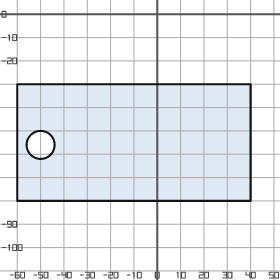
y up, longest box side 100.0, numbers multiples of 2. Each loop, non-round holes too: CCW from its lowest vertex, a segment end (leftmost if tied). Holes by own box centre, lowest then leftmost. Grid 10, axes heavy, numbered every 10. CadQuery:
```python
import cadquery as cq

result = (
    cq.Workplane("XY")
    .moveTo(-60.0, -80.0)
    .lineTo(40.0, -80.0)
    .lineTo(40.0, -30.0)
    .lineTo(-60.0, -30.0)
    .close()
    .moveTo(-50.0, -56.0)
    .circle(6.0)
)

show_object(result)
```